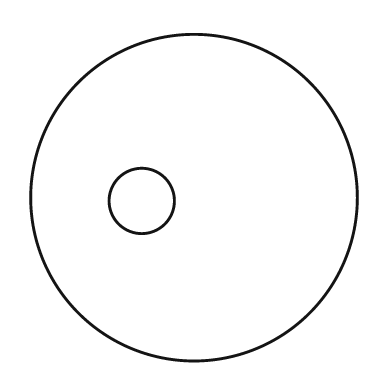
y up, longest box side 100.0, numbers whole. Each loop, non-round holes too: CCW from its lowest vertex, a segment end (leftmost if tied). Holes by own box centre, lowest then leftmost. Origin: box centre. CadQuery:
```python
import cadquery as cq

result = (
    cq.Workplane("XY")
    .moveTo(0.0, 0.0)
    .circle(50.0)
    .moveTo(-16.0, -1.0)
    .circle(10.0)
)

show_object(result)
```